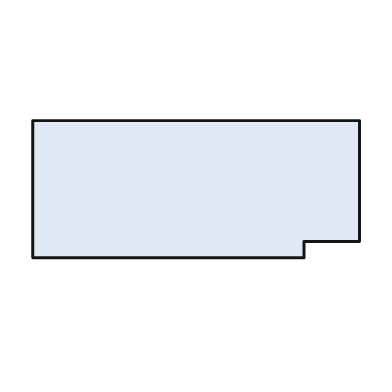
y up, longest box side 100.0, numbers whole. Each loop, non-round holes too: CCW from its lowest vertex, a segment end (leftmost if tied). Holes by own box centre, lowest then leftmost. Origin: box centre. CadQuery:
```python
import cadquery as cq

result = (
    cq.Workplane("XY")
    .moveTo(-50.0, -21.0)
    .lineTo(33.0, -21.0)
    .lineTo(33.0, -16.0)
    .lineTo(50.0, -16.0)
    .lineTo(50.0, 21.0)
    .lineTo(-50.0, 21.0)
    .close()
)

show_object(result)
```